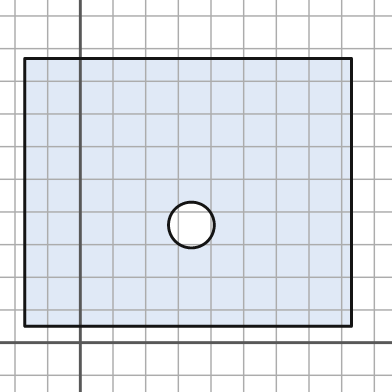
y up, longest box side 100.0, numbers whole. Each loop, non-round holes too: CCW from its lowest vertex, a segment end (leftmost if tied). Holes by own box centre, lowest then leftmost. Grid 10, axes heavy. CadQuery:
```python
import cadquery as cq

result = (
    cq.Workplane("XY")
    .moveTo(-17.0, 5.0)
    .lineTo(83.0, 5.0)
    .lineTo(83.0, 87.0)
    .lineTo(-17.0, 87.0)
    .close()
    .moveTo(34.0, 36.0)
    .circle(7.0)
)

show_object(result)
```